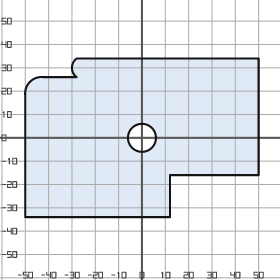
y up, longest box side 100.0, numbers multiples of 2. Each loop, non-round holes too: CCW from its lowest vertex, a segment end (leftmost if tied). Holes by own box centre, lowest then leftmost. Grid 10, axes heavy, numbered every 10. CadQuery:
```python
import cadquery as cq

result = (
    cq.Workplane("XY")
    .moveTo(-50.0, -34.0)
    .lineTo(12.0, -34.0)
    .lineTo(12.0, -16.0)
    .lineTo(50.0, -16.0)
    .lineTo(50.0, 34.0)
    .lineTo(-28.0, 34.0)
    .threePointArc((-30.0, 30.0), (-28.0, 26.0))
    .lineTo(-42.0, 26.0)
    .threePointArc((-48.0, 24.0), (-50.0, 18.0))
    .close()
    .moveTo(0.0, 0.0)
    .circle(6.0)
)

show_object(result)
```